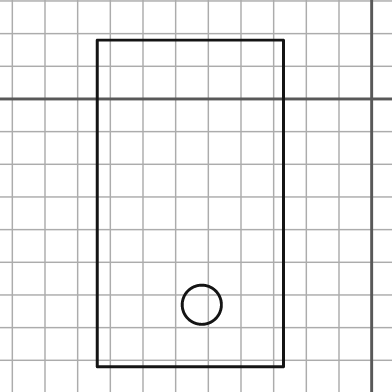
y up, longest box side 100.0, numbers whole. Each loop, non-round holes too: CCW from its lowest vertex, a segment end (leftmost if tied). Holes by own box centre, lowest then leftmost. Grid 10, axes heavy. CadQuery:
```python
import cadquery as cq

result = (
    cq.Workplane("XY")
    .moveTo(-84.0, -82.0)
    .lineTo(-27.0, -82.0)
    .lineTo(-27.0, 18.0)
    .lineTo(-84.0, 18.0)
    .close()
    .moveTo(-52.0, -63.0)
    .circle(6.0)
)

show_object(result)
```